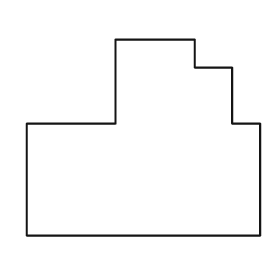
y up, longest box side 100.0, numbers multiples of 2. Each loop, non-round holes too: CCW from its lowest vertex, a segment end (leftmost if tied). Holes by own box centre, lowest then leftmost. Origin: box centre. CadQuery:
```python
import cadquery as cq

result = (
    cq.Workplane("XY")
    .moveTo(-50.0, -42.0)
    .lineTo(50.0, -42.0)
    .lineTo(50.0, 6.0)
    .lineTo(38.0, 6.0)
    .lineTo(38.0, 30.0)
    .lineTo(22.0, 30.0)
    .lineTo(22.0, 42.0)
    .lineTo(-12.0, 42.0)
    .lineTo(-12.0, 6.0)
    .lineTo(-50.0, 6.0)
    .close()
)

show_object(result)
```